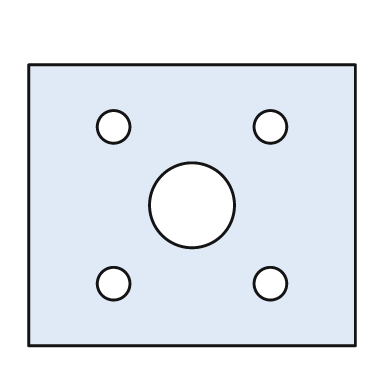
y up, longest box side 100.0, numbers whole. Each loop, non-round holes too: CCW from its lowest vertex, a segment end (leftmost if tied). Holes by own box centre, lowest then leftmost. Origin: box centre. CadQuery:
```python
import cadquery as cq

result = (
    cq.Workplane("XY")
    .moveTo(-50.0, -43.0)
    .lineTo(50.0, -43.0)
    .lineTo(50.0, 43.0)
    .lineTo(-50.0, 43.0)
    .close()
    .moveTo(-24.0, -24.0)
    .circle(5.0)
    .moveTo(24.0, -24.0)
    .circle(5.0)
    .moveTo(0.0, 0.0)
    .circle(13.0)
    .moveTo(-24.0, 24.0)
    .circle(5.0)
    .moveTo(24.0, 24.0)
    .circle(5.0)
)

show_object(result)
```